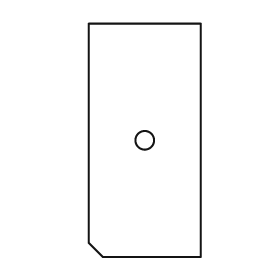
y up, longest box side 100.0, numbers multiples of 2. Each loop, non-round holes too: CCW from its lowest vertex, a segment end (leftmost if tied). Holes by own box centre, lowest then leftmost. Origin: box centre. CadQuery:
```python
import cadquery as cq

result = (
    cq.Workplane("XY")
    .moveTo(-18.0, -50.0)
    .lineTo(24.0, -50.0)
    .lineTo(24.0, 50.0)
    .lineTo(-24.0, 50.0)
    .lineTo(-24.0, -44.0)
    .close()
    .moveTo(0.0, 0.0)
    .circle(4.0)
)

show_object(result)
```